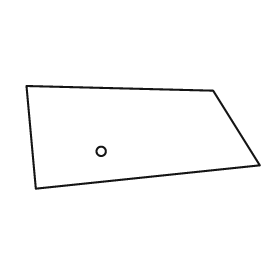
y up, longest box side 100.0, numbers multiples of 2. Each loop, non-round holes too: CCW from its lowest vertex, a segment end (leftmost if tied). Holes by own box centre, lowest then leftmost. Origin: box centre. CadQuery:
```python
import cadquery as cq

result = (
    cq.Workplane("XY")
    .moveTo(-46.0, -22.0)
    .lineTo(50.0, -12.0)
    .lineTo(30.0, 20.0)
    .lineTo(-50.0, 22.0)
    .close()
    .moveTo(-18.0, -6.0)
    .circle(2.0)
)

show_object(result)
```